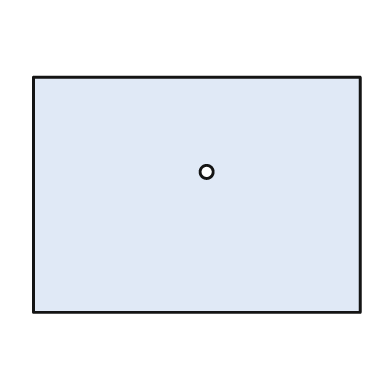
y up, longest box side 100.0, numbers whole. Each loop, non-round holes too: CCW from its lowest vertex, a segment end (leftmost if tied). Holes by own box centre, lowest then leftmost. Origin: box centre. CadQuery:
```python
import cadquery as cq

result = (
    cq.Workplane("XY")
    .moveTo(-50.0, -36.0)
    .lineTo(50.0, -36.0)
    .lineTo(50.0, 36.0)
    .lineTo(-50.0, 36.0)
    .close()
    .moveTo(3.0, 7.0)
    .circle(2.0)
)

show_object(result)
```